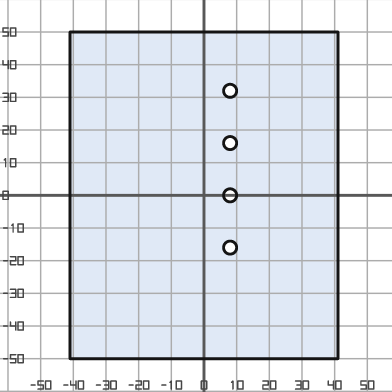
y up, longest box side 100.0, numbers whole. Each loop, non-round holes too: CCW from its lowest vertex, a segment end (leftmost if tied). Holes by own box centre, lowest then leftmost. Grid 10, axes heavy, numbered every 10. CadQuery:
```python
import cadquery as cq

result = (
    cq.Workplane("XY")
    .moveTo(-41.0, -50.0)
    .lineTo(41.0, -50.0)
    .lineTo(41.0, 50.0)
    .lineTo(-41.0, 50.0)
    .close()
    .moveTo(8.0, -16.0)
    .circle(2.0)
    .moveTo(8.0, 0.0)
    .circle(2.0)
    .moveTo(8.0, 16.0)
    .circle(2.0)
    .moveTo(8.0, 32.0)
    .circle(2.0)
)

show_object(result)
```